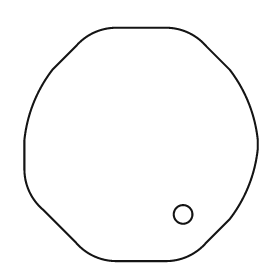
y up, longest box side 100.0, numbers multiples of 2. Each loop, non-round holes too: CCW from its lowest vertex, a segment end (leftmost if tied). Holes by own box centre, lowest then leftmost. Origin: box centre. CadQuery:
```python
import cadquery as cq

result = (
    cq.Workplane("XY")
    .moveTo(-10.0, -50.0)
    .lineTo(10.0, -50.0)
    .threePointArc((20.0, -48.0), (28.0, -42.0))
    .lineTo(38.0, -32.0)
    .threePointArc((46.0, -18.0), (50.0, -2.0))
    .lineTo(50.0, 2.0)
    .threePointArc((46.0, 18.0), (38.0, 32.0))
    .lineTo(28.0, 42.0)
    .threePointArc((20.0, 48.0), (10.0, 50.0))
    .lineTo(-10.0, 50.0)
    .threePointArc((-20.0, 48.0), (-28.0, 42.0))
    .lineTo(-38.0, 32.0)
    .threePointArc((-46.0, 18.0), (-50.0, 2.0))
    .lineTo(-50.0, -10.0)
    .threePointArc((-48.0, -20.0), (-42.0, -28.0))
    .lineTo(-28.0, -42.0)
    .threePointArc((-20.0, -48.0), (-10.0, -50.0))
    .close()
    .moveTo(18.0, -30.0)
    .circle(4.0)
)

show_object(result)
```